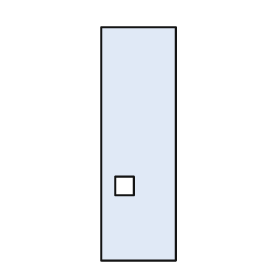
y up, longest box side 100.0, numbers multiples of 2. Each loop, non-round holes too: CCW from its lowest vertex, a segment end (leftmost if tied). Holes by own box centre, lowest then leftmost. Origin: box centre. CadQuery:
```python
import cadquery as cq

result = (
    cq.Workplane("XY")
    .moveTo(-16.0, -50.0)
    .lineTo(16.0, -50.0)
    .lineTo(16.0, 50.0)
    .lineTo(-16.0, 50.0)
    .close()
    .moveTo(-10.0, -22.0)
    .lineTo(-2.0, -22.0)
    .lineTo(-2.0, -14.0)
    .lineTo(-10.0, -14.0)
    .close()
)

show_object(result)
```